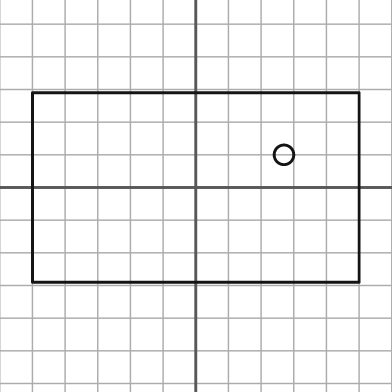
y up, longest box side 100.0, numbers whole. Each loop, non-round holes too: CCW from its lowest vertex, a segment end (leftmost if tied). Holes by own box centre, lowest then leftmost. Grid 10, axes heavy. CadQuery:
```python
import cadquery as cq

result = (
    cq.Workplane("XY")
    .moveTo(-50.0, -29.0)
    .lineTo(50.0, -29.0)
    .lineTo(50.0, 29.0)
    .lineTo(-50.0, 29.0)
    .close()
    .moveTo(27.0, 10.0)
    .circle(3.0)
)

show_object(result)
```